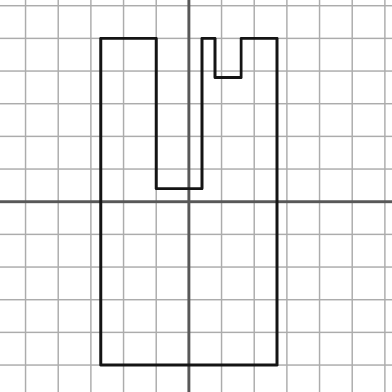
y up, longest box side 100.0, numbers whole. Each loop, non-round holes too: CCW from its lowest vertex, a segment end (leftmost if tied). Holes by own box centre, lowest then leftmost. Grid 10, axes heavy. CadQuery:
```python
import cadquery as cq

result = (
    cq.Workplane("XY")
    .moveTo(-27.0, -50.0)
    .lineTo(27.0, -50.0)
    .lineTo(27.0, 50.0)
    .lineTo(16.0, 50.0)
    .lineTo(16.0, 38.0)
    .lineTo(8.0, 38.0)
    .lineTo(8.0, 50.0)
    .lineTo(4.0, 50.0)
    .lineTo(4.0, 4.0)
    .lineTo(-10.0, 4.0)
    .lineTo(-10.0, 50.0)
    .lineTo(-27.0, 50.0)
    .close()
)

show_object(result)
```